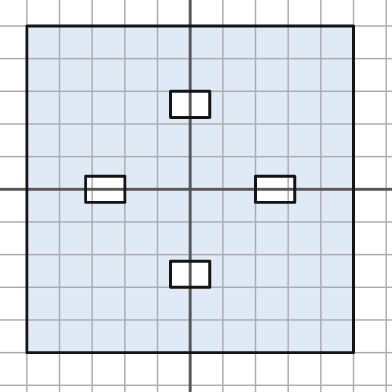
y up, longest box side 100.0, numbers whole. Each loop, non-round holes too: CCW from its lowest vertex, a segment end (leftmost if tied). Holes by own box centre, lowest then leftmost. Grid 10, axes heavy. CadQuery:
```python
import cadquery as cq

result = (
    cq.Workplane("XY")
    .moveTo(-50.0, -50.0)
    .lineTo(50.0, -50.0)
    .lineTo(50.0, 50.0)
    .lineTo(-50.0, 50.0)
    .close()
    .moveTo(-6.0, -30.0)
    .lineTo(6.0, -30.0)
    .lineTo(6.0, -22.0)
    .lineTo(-6.0, -22.0)
    .close()
    .moveTo(-32.0, -4.0)
    .lineTo(-20.0, -4.0)
    .lineTo(-20.0, 4.0)
    .lineTo(-32.0, 4.0)
    .close()
    .moveTo(20.0, -4.0)
    .lineTo(32.0, -4.0)
    .lineTo(32.0, 4.0)
    .lineTo(20.0, 4.0)
    .close()
    .moveTo(-6.0, 22.0)
    .lineTo(6.0, 22.0)
    .lineTo(6.0, 30.0)
    .lineTo(-6.0, 30.0)
    .close()
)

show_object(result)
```